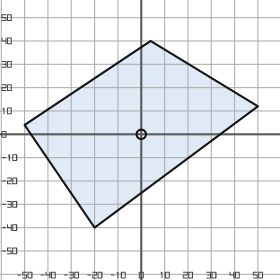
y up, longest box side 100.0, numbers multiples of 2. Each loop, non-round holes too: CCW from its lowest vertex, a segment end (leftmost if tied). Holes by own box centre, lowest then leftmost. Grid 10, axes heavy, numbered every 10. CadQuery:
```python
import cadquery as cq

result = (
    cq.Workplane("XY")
    .moveTo(-20.0, -40.0)
    .lineTo(50.0, 12.0)
    .lineTo(4.0, 40.0)
    .lineTo(-50.0, 4.0)
    .close()
    .moveTo(0.0, 0.0)
    .circle(2.0)
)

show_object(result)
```